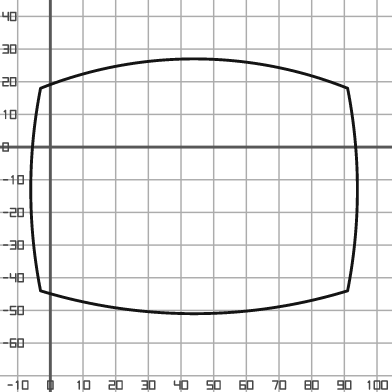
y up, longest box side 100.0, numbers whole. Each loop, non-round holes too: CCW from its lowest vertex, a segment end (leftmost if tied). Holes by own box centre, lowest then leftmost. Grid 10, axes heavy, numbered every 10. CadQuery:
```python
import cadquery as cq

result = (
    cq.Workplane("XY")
    .moveTo(-3.0, -44.0)
    .threePointArc((44.0, -51.0), (91.0, -44.0))
    .threePointArc((94.0, -13.0), (91.0, 18.0))
    .threePointArc((44.0, 27.0), (-3.0, 18.0))
    .threePointArc((-6.0, -13.0), (-3.0, -44.0))
    .close()
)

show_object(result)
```